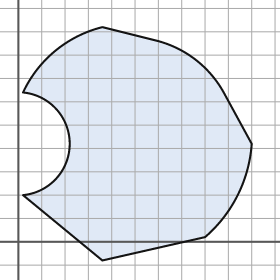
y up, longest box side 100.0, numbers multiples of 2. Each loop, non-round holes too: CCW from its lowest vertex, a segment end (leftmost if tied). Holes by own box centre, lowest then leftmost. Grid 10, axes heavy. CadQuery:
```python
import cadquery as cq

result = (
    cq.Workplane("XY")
    .moveTo(36.0, -8.0)
    .lineTo(80.0, 2.0)
    .threePointArc((94.0, 20.0), (100.0, 42.0))
    .lineTo(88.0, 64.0)
    .threePointArc((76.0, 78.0), (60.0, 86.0))
    .lineTo(36.0, 92.0)
    .threePointArc((16.0, 82.0), (2.0, 64.0))
    .threePointArc((22.0, 42.0), (2.0, 20.0))
    .close()
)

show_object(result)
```